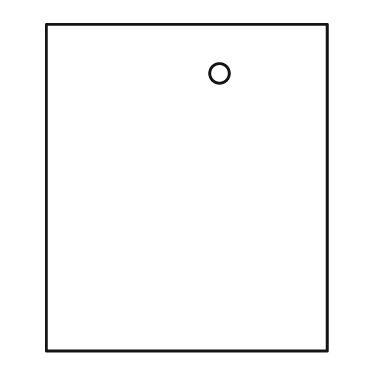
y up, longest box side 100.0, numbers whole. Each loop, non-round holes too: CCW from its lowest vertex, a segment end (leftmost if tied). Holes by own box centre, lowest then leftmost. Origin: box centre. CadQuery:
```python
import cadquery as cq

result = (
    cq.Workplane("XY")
    .moveTo(-43.0, -50.0)
    .lineTo(43.0, -50.0)
    .lineTo(43.0, 50.0)
    .lineTo(-43.0, 50.0)
    .close()
    .moveTo(10.0, 35.0)
    .circle(3.0)
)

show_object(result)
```